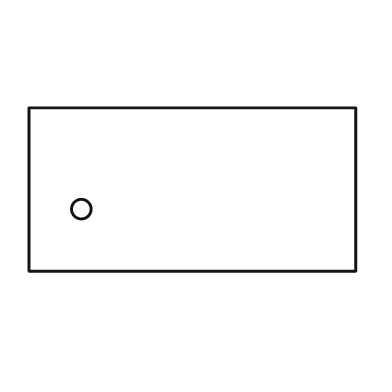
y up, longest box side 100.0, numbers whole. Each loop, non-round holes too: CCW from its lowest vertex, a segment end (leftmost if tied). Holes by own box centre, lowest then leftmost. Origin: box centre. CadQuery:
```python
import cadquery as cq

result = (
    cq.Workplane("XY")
    .moveTo(-50.0, -25.0)
    .lineTo(50.0, -25.0)
    .lineTo(50.0, 25.0)
    .lineTo(-50.0, 25.0)
    .close()
    .moveTo(-34.0, -6.0)
    .circle(3.0)
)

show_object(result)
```